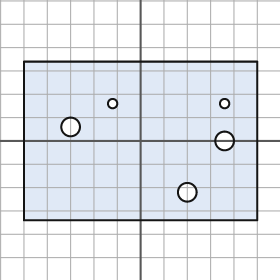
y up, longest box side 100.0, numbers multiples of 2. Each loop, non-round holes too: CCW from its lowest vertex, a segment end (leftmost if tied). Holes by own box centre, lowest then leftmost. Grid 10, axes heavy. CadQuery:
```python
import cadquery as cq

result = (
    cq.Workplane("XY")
    .moveTo(-50.0, -34.0)
    .lineTo(50.0, -34.0)
    .lineTo(50.0, 34.0)
    .lineTo(-50.0, 34.0)
    .close()
    .moveTo(20.0, -22.0)
    .circle(4.0)
    .moveTo(36.0, 0.0)
    .circle(4.0)
    .moveTo(-30.0, 6.0)
    .circle(4.0)
    .moveTo(-12.0, 16.0)
    .circle(2.0)
    .moveTo(36.0, 16.0)
    .circle(2.0)
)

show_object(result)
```